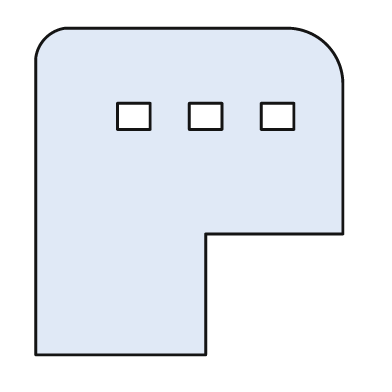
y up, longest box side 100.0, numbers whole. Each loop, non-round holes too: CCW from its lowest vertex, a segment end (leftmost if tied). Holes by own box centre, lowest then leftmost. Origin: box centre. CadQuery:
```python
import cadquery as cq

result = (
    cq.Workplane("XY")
    .moveTo(-47.0, -50.0)
    .lineTo(5.0, -50.0)
    .lineTo(5.0, -13.0)
    .lineTo(47.0, -13.0)
    .lineTo(47.0, 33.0)
    .threePointArc((42.0, 45.0), (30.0, 50.0))
    .lineTo(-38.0, 50.0)
    .threePointArc((-44.0, 47.0), (-47.0, 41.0))
    .close()
    .moveTo(-22.0, 19.0)
    .lineTo(-12.0, 19.0)
    .lineTo(-12.0, 27.0)
    .lineTo(-22.0, 27.0)
    .close()
    .moveTo(0.0, 19.0)
    .lineTo(10.0, 19.0)
    .lineTo(10.0, 27.0)
    .lineTo(0.0, 27.0)
    .close()
    .moveTo(22.0, 19.0)
    .lineTo(32.0, 19.0)
    .lineTo(32.0, 27.0)
    .lineTo(22.0, 27.0)
    .close()
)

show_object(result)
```